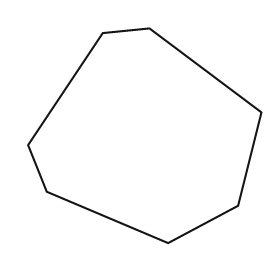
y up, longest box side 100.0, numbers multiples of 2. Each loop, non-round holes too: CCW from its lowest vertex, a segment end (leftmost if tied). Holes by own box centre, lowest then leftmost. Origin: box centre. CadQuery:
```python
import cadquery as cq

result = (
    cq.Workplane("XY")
    .moveTo(10.0, -46.0)
    .lineTo(40.0, -30.0)
    .lineTo(50.0, 10.0)
    .lineTo(2.0, 46.0)
    .lineTo(-18.0, 44.0)
    .lineTo(-50.0, -4.0)
    .lineTo(-42.0, -24.0)
    .close()
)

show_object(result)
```